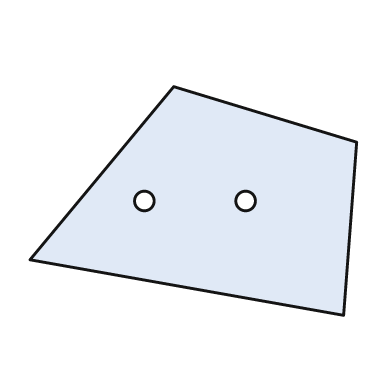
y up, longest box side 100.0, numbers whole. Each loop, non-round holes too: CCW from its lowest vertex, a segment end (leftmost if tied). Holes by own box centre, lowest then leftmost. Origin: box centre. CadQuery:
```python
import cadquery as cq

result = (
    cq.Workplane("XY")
    .moveTo(46.0, -35.0)
    .lineTo(50.0, 18.0)
    .lineTo(-6.0, 35.0)
    .lineTo(-50.0, -18.0)
    .close()
    .moveTo(-15.0, 0.0)
    .circle(3.0)
    .moveTo(16.0, 0.0)
    .circle(3.0)
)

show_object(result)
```